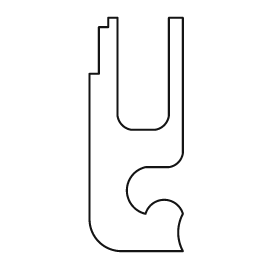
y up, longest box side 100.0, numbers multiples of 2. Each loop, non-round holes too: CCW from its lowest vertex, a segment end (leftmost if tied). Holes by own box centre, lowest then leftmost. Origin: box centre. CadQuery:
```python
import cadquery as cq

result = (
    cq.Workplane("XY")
    .moveTo(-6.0, -50.0)
    .lineTo(20.0, -50.0)
    .threePointArc((18.0, -42.0), (20.0, -34.0))
    .threePointArc((12.0, -28.0), (4.0, -34.0))
    .threePointArc((-4.0, -24.0), (4.0, -14.0))
    .lineTo(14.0, -14.0)
    .threePointArc((18.0, -12.0), (20.0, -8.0))
    .lineTo(20.0, 50.0)
    .lineTo(14.0, 50.0)
    .lineTo(14.0, 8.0)
    .threePointArc((12.0, 4.0), (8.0, 2.0))
    .lineTo(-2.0, 2.0)
    .threePointArc((-6.0, 4.0), (-8.0, 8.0))
    .lineTo(-8.0, 50.0)
    .lineTo(-12.0, 50.0)
    .lineTo(-12.0, 46.0)
    .lineTo(-16.0, 46.0)
    .lineTo(-16.0, 26.0)
    .lineTo(-20.0, 26.0)
    .lineTo(-20.0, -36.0)
    .threePointArc((-16.0, -46.0), (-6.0, -50.0))
    .close()
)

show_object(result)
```